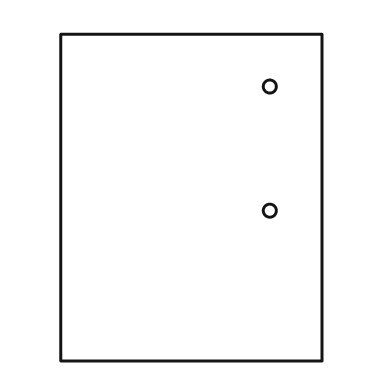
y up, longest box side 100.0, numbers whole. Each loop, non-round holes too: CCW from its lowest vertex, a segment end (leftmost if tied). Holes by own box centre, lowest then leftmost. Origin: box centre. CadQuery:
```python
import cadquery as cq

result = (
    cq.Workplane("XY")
    .moveTo(-40.0, -50.0)
    .lineTo(40.0, -50.0)
    .lineTo(40.0, 50.0)
    .lineTo(-40.0, 50.0)
    .close()
    .moveTo(24.0, -4.0)
    .circle(2.0)
    .moveTo(24.0, 34.0)
    .circle(2.0)
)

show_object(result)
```